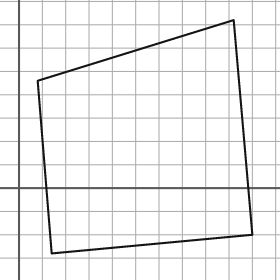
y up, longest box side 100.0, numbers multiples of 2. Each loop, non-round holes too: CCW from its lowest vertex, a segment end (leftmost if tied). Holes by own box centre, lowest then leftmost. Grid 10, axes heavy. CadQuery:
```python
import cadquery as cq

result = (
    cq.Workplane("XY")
    .moveTo(14.0, -28.0)
    .lineTo(100.0, -20.0)
    .lineTo(92.0, 72.0)
    .lineTo(8.0, 46.0)
    .close()
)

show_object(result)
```